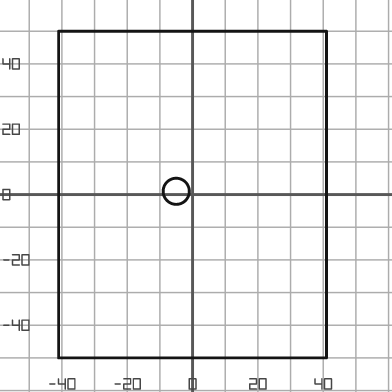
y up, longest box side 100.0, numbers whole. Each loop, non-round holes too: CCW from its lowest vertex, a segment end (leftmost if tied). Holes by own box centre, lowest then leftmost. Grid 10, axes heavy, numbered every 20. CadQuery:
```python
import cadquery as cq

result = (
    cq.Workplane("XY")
    .moveTo(-41.0, -50.0)
    .lineTo(41.0, -50.0)
    .lineTo(41.0, 50.0)
    .lineTo(-41.0, 50.0)
    .close()
    .moveTo(-5.0, 1.0)
    .circle(4.0)
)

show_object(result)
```